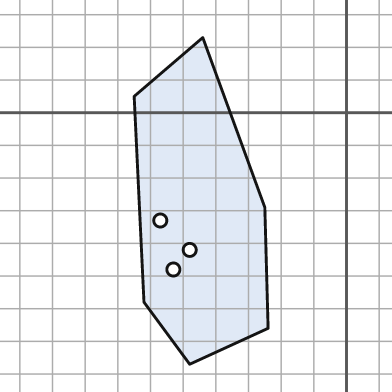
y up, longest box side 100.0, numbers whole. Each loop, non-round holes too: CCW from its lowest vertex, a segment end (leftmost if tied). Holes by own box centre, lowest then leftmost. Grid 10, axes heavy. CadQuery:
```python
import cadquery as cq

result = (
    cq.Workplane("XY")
    .moveTo(-48.0, -77.0)
    .lineTo(-24.0, -66.0)
    .lineTo(-25.0, -29.0)
    .lineTo(-44.0, 23.0)
    .lineTo(-65.0, 5.0)
    .lineTo(-62.0, -58.0)
    .close()
    .moveTo(-53.0, -48.0)
    .circle(2.0)
    .moveTo(-48.0, -42.0)
    .circle(2.0)
    .moveTo(-57.0, -33.0)
    .circle(2.0)
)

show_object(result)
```